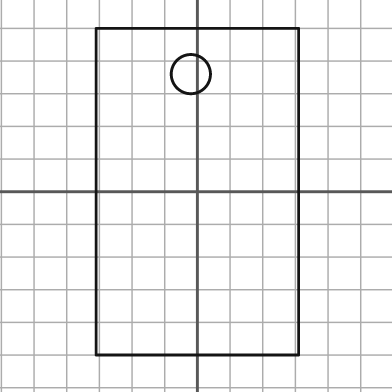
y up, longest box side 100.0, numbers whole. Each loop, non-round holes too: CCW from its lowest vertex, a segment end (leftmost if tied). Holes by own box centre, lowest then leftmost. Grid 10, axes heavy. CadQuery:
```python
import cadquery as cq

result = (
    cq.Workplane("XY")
    .moveTo(-31.0, -50.0)
    .lineTo(31.0, -50.0)
    .lineTo(31.0, 50.0)
    .lineTo(-31.0, 50.0)
    .close()
    .moveTo(-2.0, 36.0)
    .circle(6.0)
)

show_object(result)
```